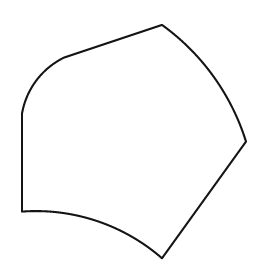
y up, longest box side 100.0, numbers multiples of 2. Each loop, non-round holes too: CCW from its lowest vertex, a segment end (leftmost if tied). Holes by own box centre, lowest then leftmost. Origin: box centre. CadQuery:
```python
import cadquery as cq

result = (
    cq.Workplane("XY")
    .moveTo(12.0, -50.0)
    .lineTo(48.0, 0.0)
    .threePointArc((34.0, 28.0), (12.0, 50.0))
    .lineTo(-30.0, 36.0)
    .threePointArc((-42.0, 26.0), (-48.0, 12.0))
    .lineTo(-48.0, -30.0)
    .threePointArc((-16.0, -34.0), (12.0, -50.0))
    .close()
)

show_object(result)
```